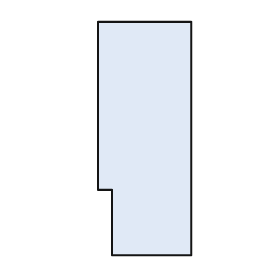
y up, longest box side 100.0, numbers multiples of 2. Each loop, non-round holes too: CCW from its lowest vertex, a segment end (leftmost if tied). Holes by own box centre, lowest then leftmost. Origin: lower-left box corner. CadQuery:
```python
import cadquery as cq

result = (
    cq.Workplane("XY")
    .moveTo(6.0, 0.0)
    .lineTo(40.0, 0.0)
    .lineTo(40.0, 100.0)
    .lineTo(0.0, 100.0)
    .lineTo(0.0, 28.0)
    .lineTo(6.0, 28.0)
    .close()
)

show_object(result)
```